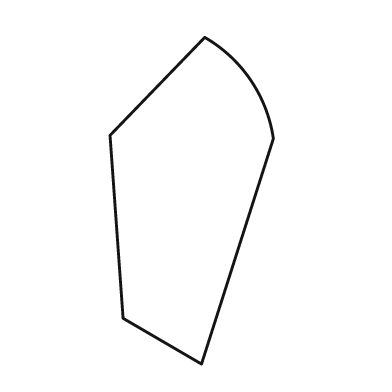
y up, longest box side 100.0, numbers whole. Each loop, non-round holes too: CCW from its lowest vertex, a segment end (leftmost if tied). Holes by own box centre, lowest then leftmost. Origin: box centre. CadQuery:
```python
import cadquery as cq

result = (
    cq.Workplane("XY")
    .moveTo(3.0, -50.0)
    .lineTo(25.0, 19.0)
    .threePointArc((18.0, 37.0), (4.0, 50.0))
    .lineTo(-25.0, 20.0)
    .lineTo(-21.0, -36.0)
    .close()
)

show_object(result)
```